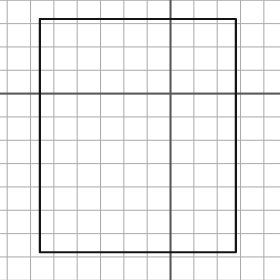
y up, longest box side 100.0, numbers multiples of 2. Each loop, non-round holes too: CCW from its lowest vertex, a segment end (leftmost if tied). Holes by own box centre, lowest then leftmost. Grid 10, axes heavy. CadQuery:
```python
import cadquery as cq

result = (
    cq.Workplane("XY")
    .moveTo(-56.0, -68.0)
    .lineTo(28.0, -68.0)
    .lineTo(28.0, 32.0)
    .lineTo(-56.0, 32.0)
    .close()
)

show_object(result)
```